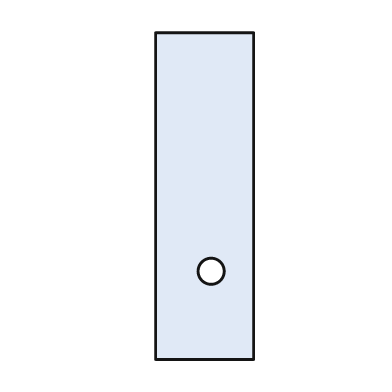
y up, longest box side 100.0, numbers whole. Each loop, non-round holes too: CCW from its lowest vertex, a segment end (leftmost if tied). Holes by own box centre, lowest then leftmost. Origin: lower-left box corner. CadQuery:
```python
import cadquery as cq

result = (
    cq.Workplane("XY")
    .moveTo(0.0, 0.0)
    .lineTo(30.0, 0.0)
    .lineTo(30.0, 100.0)
    .lineTo(0.0, 100.0)
    .close()
    .moveTo(17.0, 27.0)
    .circle(4.0)
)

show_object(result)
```